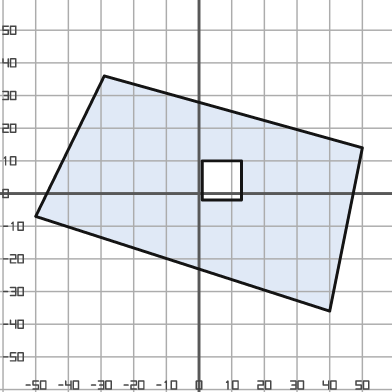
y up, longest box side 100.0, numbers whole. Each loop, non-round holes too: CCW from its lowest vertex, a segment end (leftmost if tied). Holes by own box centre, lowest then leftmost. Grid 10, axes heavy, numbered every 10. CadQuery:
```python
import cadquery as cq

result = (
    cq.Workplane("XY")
    .moveTo(40.0, -36.0)
    .lineTo(50.0, 14.0)
    .lineTo(-29.0, 36.0)
    .lineTo(-50.0, -7.0)
    .close()
    .moveTo(1.0, -2.0)
    .lineTo(13.0, -2.0)
    .lineTo(13.0, 10.0)
    .lineTo(1.0, 10.0)
    .close()
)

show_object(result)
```